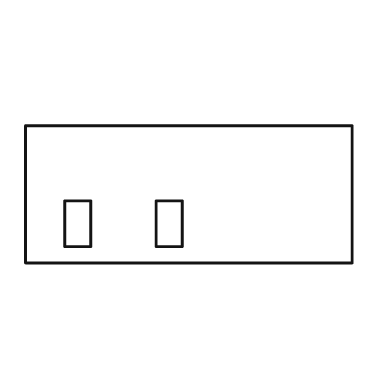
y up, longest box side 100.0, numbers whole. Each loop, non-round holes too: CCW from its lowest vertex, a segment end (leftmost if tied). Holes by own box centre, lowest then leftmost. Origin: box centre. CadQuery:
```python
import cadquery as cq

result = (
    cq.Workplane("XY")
    .moveTo(-50.0, -21.0)
    .lineTo(50.0, -21.0)
    .lineTo(50.0, 21.0)
    .lineTo(-50.0, 21.0)
    .close()
    .moveTo(-38.0, -16.0)
    .lineTo(-30.0, -16.0)
    .lineTo(-30.0, -2.0)
    .lineTo(-38.0, -2.0)
    .close()
    .moveTo(-10.0, -16.0)
    .lineTo(-2.0, -16.0)
    .lineTo(-2.0, -2.0)
    .lineTo(-10.0, -2.0)
    .close()
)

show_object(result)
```